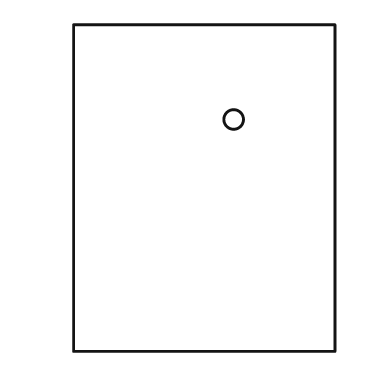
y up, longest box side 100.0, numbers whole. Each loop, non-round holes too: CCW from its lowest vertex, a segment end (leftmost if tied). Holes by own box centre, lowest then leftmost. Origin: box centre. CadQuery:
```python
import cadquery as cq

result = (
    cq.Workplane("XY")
    .moveTo(-40.0, -50.0)
    .lineTo(40.0, -50.0)
    .lineTo(40.0, 50.0)
    .lineTo(-40.0, 50.0)
    .close()
    .moveTo(9.0, 21.0)
    .circle(3.0)
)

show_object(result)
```